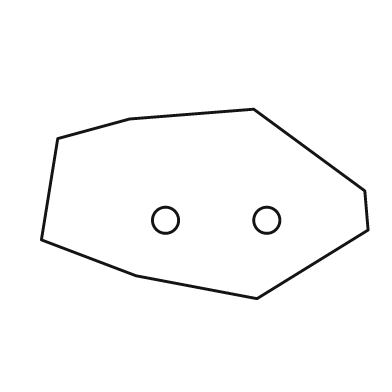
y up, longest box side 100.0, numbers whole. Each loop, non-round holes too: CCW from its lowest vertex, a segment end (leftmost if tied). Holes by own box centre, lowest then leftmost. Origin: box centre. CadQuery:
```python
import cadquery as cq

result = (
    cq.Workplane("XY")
    .moveTo(16.0, -29.0)
    .lineTo(50.0, -8.0)
    .lineTo(49.0, 4.0)
    .lineTo(15.0, 29.0)
    .lineTo(-23.0, 26.0)
    .lineTo(-45.0, 20.0)
    .lineTo(-50.0, -11.0)
    .lineTo(-21.0, -22.0)
    .close()
    .moveTo(-12.0, -5.0)
    .circle(4.0)
    .moveTo(19.0, -5.0)
    .circle(4.0)
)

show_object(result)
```